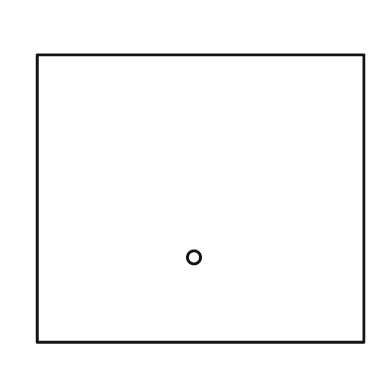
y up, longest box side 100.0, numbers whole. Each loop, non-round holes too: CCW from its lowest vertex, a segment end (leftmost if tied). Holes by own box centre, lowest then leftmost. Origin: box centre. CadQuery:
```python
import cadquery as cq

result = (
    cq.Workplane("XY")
    .moveTo(-50.0, -44.0)
    .lineTo(50.0, -44.0)
    .lineTo(50.0, 44.0)
    .lineTo(-50.0, 44.0)
    .close()
    .moveTo(-2.0, -18.0)
    .circle(2.0)
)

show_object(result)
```